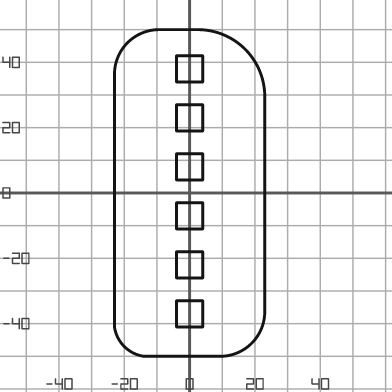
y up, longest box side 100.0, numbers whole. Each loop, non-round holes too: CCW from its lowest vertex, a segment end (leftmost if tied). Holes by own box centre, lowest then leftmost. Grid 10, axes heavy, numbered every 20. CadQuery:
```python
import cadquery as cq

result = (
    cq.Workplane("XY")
    .moveTo(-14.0, -50.0)
    .lineTo(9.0, -50.0)
    .threePointArc((19.0, -46.0), (23.0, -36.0))
    .lineTo(23.0, 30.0)
    .threePointArc((17.0, 44.0), (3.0, 50.0))
    .lineTo(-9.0, 50.0)
    .threePointArc((-19.0, 46.0), (-23.0, 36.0))
    .lineTo(-23.0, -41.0)
    .threePointArc((-20.0, -47.0), (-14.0, -50.0))
    .close()
    .moveTo(-4.0, -41.0)
    .lineTo(4.0, -41.0)
    .lineTo(4.0, -33.0)
    .lineTo(-4.0, -33.0)
    .close()
    .moveTo(-4.0, -26.0)
    .lineTo(4.0, -26.0)
    .lineTo(4.0, -18.0)
    .lineTo(-4.0, -18.0)
    .close()
    .moveTo(-4.0, -11.0)
    .lineTo(4.0, -11.0)
    .lineTo(4.0, -3.0)
    .lineTo(-4.0, -3.0)
    .close()
    .moveTo(-4.0, 4.0)
    .lineTo(4.0, 4.0)
    .lineTo(4.0, 12.0)
    .lineTo(-4.0, 12.0)
    .close()
    .moveTo(-4.0, 19.0)
    .lineTo(4.0, 19.0)
    .lineTo(4.0, 27.0)
    .lineTo(-4.0, 27.0)
    .close()
    .moveTo(-4.0, 34.0)
    .lineTo(4.0, 34.0)
    .lineTo(4.0, 42.0)
    .lineTo(-4.0, 42.0)
    .close()
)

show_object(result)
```